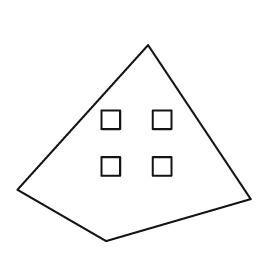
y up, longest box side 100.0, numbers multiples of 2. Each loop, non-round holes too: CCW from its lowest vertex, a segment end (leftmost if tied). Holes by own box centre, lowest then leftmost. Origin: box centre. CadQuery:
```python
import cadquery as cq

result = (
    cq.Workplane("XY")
    .moveTo(-12.0, -42.0)
    .lineTo(50.0, -24.0)
    .lineTo(6.0, 42.0)
    .lineTo(-50.0, -20.0)
    .close()
    .moveTo(-14.0, -14.0)
    .lineTo(-6.0, -14.0)
    .lineTo(-6.0, -6.0)
    .lineTo(-14.0, -6.0)
    .close()
    .moveTo(8.0, -14.0)
    .lineTo(16.0, -14.0)
    .lineTo(16.0, -6.0)
    .lineTo(8.0, -6.0)
    .close()
    .moveTo(-14.0, 6.0)
    .lineTo(-6.0, 6.0)
    .lineTo(-6.0, 14.0)
    .lineTo(-14.0, 14.0)
    .close()
    .moveTo(8.0, 6.0)
    .lineTo(16.0, 6.0)
    .lineTo(16.0, 14.0)
    .lineTo(8.0, 14.0)
    .close()
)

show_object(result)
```